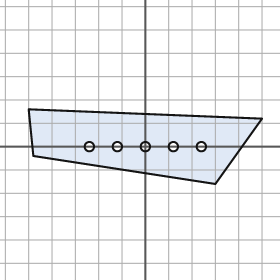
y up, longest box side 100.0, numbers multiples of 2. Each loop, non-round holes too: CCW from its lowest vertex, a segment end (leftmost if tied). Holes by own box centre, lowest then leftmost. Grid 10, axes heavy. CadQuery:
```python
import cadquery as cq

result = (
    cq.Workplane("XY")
    .moveTo(30.0, -16.0)
    .lineTo(50.0, 12.0)
    .lineTo(-50.0, 16.0)
    .lineTo(-48.0, -4.0)
    .close()
    .moveTo(-24.0, 0.0)
    .circle(2.0)
    .moveTo(-12.0, 0.0)
    .circle(2.0)
    .moveTo(0.0, 0.0)
    .circle(2.0)
    .moveTo(12.0, 0.0)
    .circle(2.0)
    .moveTo(24.0, 0.0)
    .circle(2.0)
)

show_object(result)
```